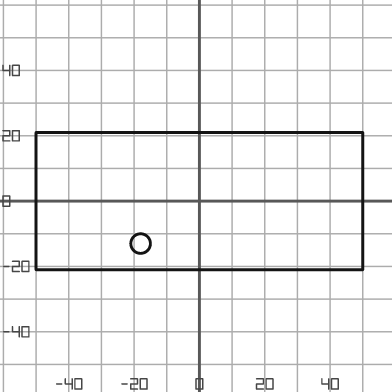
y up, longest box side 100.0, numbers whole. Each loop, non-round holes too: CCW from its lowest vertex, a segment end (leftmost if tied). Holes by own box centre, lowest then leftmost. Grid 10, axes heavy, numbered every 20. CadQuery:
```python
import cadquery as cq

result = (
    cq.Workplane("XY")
    .moveTo(-50.0, -21.0)
    .lineTo(50.0, -21.0)
    .lineTo(50.0, 21.0)
    .lineTo(-50.0, 21.0)
    .close()
    .moveTo(-18.0, -13.0)
    .circle(3.0)
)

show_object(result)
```